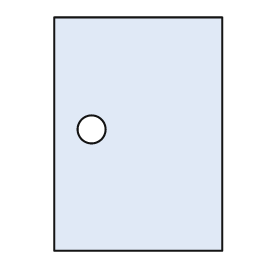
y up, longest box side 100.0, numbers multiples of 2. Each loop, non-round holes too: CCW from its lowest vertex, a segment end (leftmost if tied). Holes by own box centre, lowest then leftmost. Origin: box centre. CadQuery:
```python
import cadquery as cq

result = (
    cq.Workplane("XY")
    .moveTo(-36.0, -50.0)
    .lineTo(36.0, -50.0)
    .lineTo(36.0, 50.0)
    .lineTo(-36.0, 50.0)
    .close()
    .moveTo(-20.0, 2.0)
    .circle(6.0)
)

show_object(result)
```